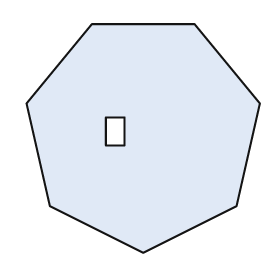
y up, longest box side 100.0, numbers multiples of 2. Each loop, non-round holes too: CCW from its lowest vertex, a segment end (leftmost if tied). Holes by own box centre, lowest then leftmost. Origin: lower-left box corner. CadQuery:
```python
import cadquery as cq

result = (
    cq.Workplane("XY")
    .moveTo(50.0, 0.0)
    .lineTo(90.0, 20.0)
    .lineTo(100.0, 64.0)
    .lineTo(72.0, 98.0)
    .lineTo(28.0, 98.0)
    .lineTo(0.0, 64.0)
    .lineTo(10.0, 20.0)
    .close()
    .moveTo(34.0, 46.0)
    .lineTo(42.0, 46.0)
    .lineTo(42.0, 58.0)
    .lineTo(34.0, 58.0)
    .close()
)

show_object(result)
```